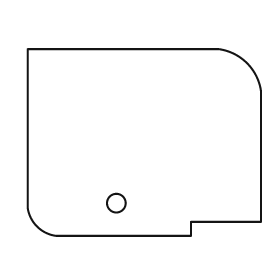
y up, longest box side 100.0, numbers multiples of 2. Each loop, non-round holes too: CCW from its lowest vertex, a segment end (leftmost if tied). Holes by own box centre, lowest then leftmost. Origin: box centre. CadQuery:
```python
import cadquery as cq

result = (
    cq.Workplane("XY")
    .moveTo(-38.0, -40.0)
    .lineTo(20.0, -40.0)
    .lineTo(20.0, -34.0)
    .lineTo(50.0, -34.0)
    .lineTo(50.0, 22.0)
    .threePointArc((44.0, 34.0), (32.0, 40.0))
    .lineTo(-50.0, 40.0)
    .lineTo(-50.0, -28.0)
    .threePointArc((-46.0, -36.0), (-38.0, -40.0))
    .close()
    .moveTo(-12.0, -26.0)
    .circle(4.0)
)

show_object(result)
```